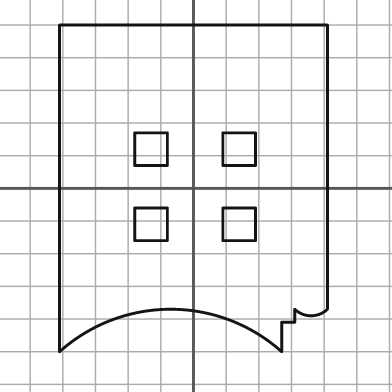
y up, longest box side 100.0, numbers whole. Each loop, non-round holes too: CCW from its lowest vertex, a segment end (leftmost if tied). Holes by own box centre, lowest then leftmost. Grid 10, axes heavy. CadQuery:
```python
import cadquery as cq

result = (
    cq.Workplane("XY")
    .moveTo(-41.0, -50.0)
    .threePointArc((-7.0, -37.0), (27.0, -50.0))
    .lineTo(27.0, -41.0)
    .lineTo(31.0, -41.0)
    .lineTo(31.0, -37.0)
    .threePointArc((36.0, -39.0), (41.0, -37.0))
    .lineTo(41.0, 50.0)
    .lineTo(-41.0, 50.0)
    .close()
    .moveTo(-18.0, -16.0)
    .lineTo(-8.0, -16.0)
    .lineTo(-8.0, -6.0)
    .lineTo(-18.0, -6.0)
    .close()
    .moveTo(9.0, -16.0)
    .lineTo(19.0, -16.0)
    .lineTo(19.0, -6.0)
    .lineTo(9.0, -6.0)
    .close()
    .moveTo(-18.0, 7.0)
    .lineTo(-8.0, 7.0)
    .lineTo(-8.0, 17.0)
    .lineTo(-18.0, 17.0)
    .close()
    .moveTo(9.0, 7.0)
    .lineTo(19.0, 7.0)
    .lineTo(19.0, 17.0)
    .lineTo(9.0, 17.0)
    .close()
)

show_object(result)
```